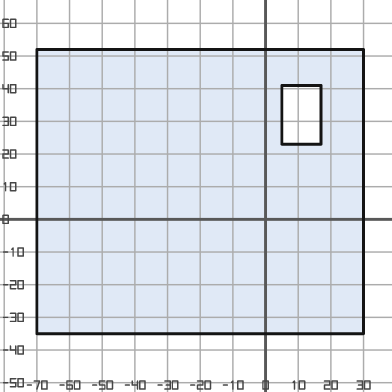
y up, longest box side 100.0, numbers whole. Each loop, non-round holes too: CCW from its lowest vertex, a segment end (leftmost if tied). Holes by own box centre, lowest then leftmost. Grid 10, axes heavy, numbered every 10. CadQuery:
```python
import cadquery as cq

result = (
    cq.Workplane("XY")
    .moveTo(-70.0, -35.0)
    .lineTo(30.0, -35.0)
    .lineTo(30.0, 52.0)
    .lineTo(-70.0, 52.0)
    .close()
    .moveTo(5.0, 23.0)
    .lineTo(17.0, 23.0)
    .lineTo(17.0, 41.0)
    .lineTo(5.0, 41.0)
    .close()
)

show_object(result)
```